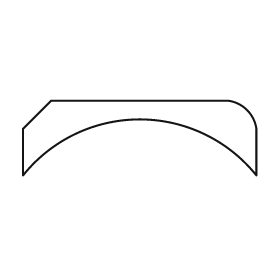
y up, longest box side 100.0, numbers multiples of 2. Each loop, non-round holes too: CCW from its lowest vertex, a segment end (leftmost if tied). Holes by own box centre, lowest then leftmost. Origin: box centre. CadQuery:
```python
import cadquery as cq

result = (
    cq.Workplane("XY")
    .moveTo(-50.0, -16.0)
    .threePointArc((0.0, 8.0), (50.0, -16.0))
    .lineTo(50.0, 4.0)
    .threePointArc((46.0, 12.0), (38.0, 16.0))
    .lineTo(-38.0, 16.0)
    .lineTo(-50.0, 4.0)
    .close()
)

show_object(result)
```